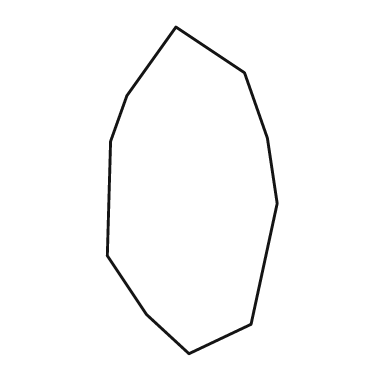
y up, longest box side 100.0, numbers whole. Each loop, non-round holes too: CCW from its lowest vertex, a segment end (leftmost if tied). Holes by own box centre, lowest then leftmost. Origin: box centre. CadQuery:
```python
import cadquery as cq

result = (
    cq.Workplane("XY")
    .moveTo(-1.0, -50.0)
    .lineTo(18.0, -41.0)
    .lineTo(26.0, -4.0)
    .lineTo(23.0, 16.0)
    .lineTo(16.0, 36.0)
    .lineTo(-5.0, 50.0)
    .lineTo(-20.0, 29.0)
    .lineTo(-25.0, 15.0)
    .lineTo(-26.0, -20.0)
    .lineTo(-14.0, -38.0)
    .close()
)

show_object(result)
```